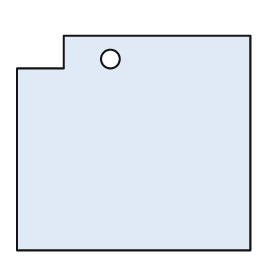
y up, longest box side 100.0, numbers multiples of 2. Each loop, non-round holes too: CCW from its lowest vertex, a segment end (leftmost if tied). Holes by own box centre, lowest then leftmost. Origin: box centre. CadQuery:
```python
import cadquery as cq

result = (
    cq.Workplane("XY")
    .moveTo(-50.0, -46.0)
    .lineTo(50.0, -46.0)
    .lineTo(50.0, 46.0)
    .lineTo(-30.0, 46.0)
    .lineTo(-30.0, 32.0)
    .lineTo(-50.0, 32.0)
    .close()
    .moveTo(-10.0, 36.0)
    .circle(4.0)
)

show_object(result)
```